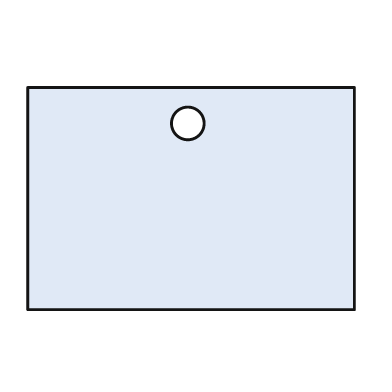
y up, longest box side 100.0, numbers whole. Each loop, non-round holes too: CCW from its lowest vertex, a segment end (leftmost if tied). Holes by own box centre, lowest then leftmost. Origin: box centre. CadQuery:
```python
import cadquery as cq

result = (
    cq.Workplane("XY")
    .moveTo(-50.0, -34.0)
    .lineTo(50.0, -34.0)
    .lineTo(50.0, 34.0)
    .lineTo(-50.0, 34.0)
    .close()
    .moveTo(-1.0, 23.0)
    .circle(5.0)
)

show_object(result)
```